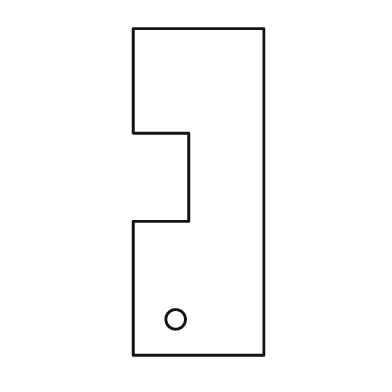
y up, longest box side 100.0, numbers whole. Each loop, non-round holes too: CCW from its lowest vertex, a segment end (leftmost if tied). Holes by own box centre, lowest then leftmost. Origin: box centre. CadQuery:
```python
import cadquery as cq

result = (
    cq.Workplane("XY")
    .moveTo(-20.0, -50.0)
    .lineTo(20.0, -50.0)
    .lineTo(20.0, 50.0)
    .lineTo(-20.0, 50.0)
    .lineTo(-20.0, 18.0)
    .lineTo(-3.0, 18.0)
    .lineTo(-3.0, -9.0)
    .lineTo(-20.0, -9.0)
    .close()
    .moveTo(-7.0, -39.0)
    .circle(3.0)
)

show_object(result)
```